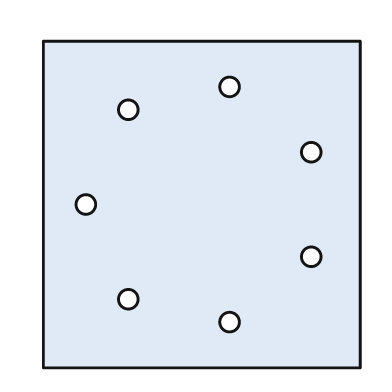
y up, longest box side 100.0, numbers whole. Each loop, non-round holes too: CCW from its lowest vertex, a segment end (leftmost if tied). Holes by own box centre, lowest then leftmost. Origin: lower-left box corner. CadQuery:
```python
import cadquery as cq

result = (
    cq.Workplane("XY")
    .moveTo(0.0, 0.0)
    .lineTo(97.0, 0.0)
    .lineTo(97.0, 100.0)
    .lineTo(0.0, 100.0)
    .close()
    .moveTo(57.0, 14.0)
    .circle(3.0)
    .moveTo(26.0, 21.0)
    .circle(3.0)
    .moveTo(82.0, 34.0)
    .circle(3.0)
    .moveTo(13.0, 50.0)
    .circle(3.0)
    .moveTo(82.0, 66.0)
    .circle(3.0)
    .moveTo(26.0, 79.0)
    .circle(3.0)
    .moveTo(57.0, 86.0)
    .circle(3.0)
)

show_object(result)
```